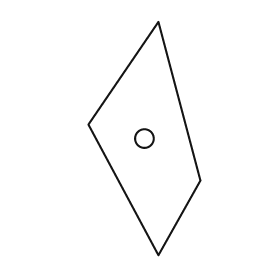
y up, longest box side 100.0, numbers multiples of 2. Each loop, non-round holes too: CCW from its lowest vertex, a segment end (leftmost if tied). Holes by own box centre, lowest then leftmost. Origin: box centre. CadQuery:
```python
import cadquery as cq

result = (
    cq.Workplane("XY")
    .moveTo(6.0, -50.0)
    .lineTo(24.0, -18.0)
    .lineTo(6.0, 50.0)
    .lineTo(-24.0, 6.0)
    .close()
    .moveTo(0.0, 0.0)
    .circle(4.0)
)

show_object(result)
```